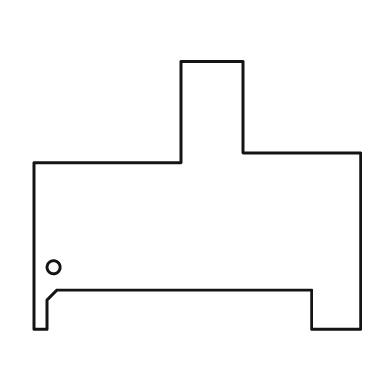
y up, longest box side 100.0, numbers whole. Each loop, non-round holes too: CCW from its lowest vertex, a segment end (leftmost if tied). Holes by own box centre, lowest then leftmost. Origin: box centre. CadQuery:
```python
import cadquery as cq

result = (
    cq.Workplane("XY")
    .moveTo(-50.0, -41.0)
    .lineTo(-46.0, -41.0)
    .lineTo(-46.0, -32.0)
    .lineTo(-43.0, -29.0)
    .lineTo(35.0, -29.0)
    .lineTo(35.0, -41.0)
    .lineTo(50.0, -41.0)
    .lineTo(50.0, 13.0)
    .lineTo(14.0, 13.0)
    .lineTo(14.0, 41.0)
    .lineTo(-5.0, 41.0)
    .lineTo(-5.0, 10.0)
    .lineTo(-50.0, 10.0)
    .close()
    .moveTo(-44.0, -22.0)
    .circle(2.0)
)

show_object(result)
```